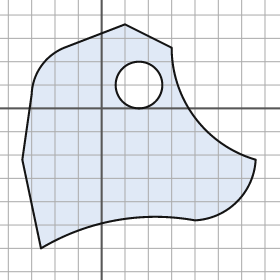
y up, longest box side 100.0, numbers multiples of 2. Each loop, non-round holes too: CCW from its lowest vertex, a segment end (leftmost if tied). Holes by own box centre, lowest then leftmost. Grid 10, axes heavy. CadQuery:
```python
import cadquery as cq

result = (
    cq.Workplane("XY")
    .moveTo(-26.0, -60.0)
    .threePointArc((6.0, -48.0), (40.0, -48.0))
    .threePointArc((58.0, -40.0), (66.0, -22.0))
    .threePointArc((40.0, -4.0), (30.0, 26.0))
    .lineTo(10.0, 36.0)
    .lineTo(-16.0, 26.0)
    .threePointArc((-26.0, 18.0), (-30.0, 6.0))
    .lineTo(-34.0, -22.0)
    .close()
    .moveTo(16.0, 10.0)
    .circle(10.0)
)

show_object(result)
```